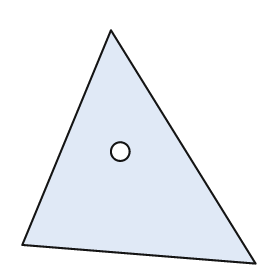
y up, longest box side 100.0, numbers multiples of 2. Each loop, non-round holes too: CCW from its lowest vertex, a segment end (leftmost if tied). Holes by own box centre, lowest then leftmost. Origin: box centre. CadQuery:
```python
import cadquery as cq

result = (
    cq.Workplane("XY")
    .moveTo(50.0, -50.0)
    .lineTo(-12.0, 50.0)
    .lineTo(-50.0, -42.0)
    .close()
    .moveTo(-8.0, -2.0)
    .circle(4.0)
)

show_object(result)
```